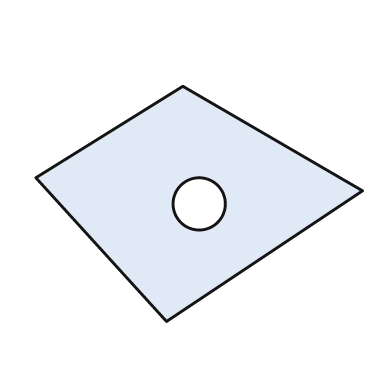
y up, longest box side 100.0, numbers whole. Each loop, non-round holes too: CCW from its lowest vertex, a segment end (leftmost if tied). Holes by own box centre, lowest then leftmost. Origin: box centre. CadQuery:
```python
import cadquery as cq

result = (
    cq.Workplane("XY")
    .moveTo(-10.0, -36.0)
    .lineTo(50.0, 4.0)
    .lineTo(-5.0, 36.0)
    .lineTo(-50.0, 8.0)
    .close()
    .moveTo(0.0, 0.0)
    .circle(8.0)
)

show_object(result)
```